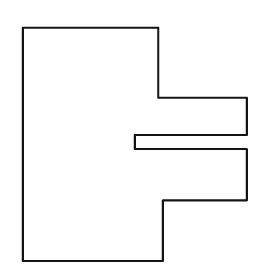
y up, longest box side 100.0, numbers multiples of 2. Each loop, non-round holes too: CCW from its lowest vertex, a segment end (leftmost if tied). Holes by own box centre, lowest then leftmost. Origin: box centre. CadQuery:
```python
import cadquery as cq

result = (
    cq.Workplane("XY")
    .moveTo(-48.0, -50.0)
    .lineTo(12.0, -50.0)
    .lineTo(12.0, -24.0)
    .lineTo(48.0, -24.0)
    .lineTo(48.0, -2.0)
    .lineTo(0.0, -2.0)
    .lineTo(0.0, 4.0)
    .lineTo(48.0, 4.0)
    .lineTo(48.0, 20.0)
    .lineTo(10.0, 20.0)
    .lineTo(10.0, 50.0)
    .lineTo(-48.0, 50.0)
    .close()
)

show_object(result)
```